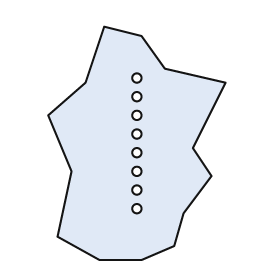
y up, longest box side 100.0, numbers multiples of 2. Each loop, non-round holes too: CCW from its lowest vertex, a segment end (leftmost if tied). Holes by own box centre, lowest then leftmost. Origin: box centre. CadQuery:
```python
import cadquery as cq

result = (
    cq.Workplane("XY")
    .moveTo(-16.0, -50.0)
    .lineTo(2.0, -50.0)
    .lineTo(16.0, -44.0)
    .lineTo(20.0, -30.0)
    .lineTo(32.0, -14.0)
    .lineTo(24.0, -2.0)
    .lineTo(38.0, 26.0)
    .lineTo(12.0, 32.0)
    .lineTo(2.0, 46.0)
    .lineTo(-14.0, 50.0)
    .lineTo(-22.0, 26.0)
    .lineTo(-38.0, 12.0)
    .lineTo(-28.0, -12.0)
    .lineTo(-34.0, -40.0)
    .close()
    .moveTo(0.0, -28.0)
    .circle(2.0)
    .moveTo(0.0, -20.0)
    .circle(2.0)
    .moveTo(0.0, -12.0)
    .circle(2.0)
    .moveTo(0.0, -4.0)
    .circle(2.0)
    .moveTo(0.0, 4.0)
    .circle(2.0)
    .moveTo(0.0, 12.0)
    .circle(2.0)
    .moveTo(0.0, 20.0)
    .circle(2.0)
    .moveTo(0.0, 28.0)
    .circle(2.0)
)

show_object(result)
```